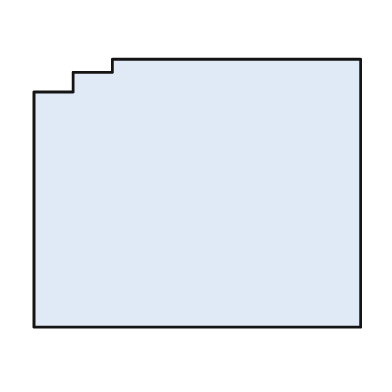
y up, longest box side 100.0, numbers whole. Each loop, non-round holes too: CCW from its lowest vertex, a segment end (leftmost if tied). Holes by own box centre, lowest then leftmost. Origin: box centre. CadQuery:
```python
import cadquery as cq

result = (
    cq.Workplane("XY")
    .moveTo(-50.0, -41.0)
    .lineTo(50.0, -41.0)
    .lineTo(50.0, 41.0)
    .lineTo(-26.0, 41.0)
    .lineTo(-26.0, 37.0)
    .lineTo(-38.0, 37.0)
    .lineTo(-38.0, 31.0)
    .lineTo(-50.0, 31.0)
    .close()
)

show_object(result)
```